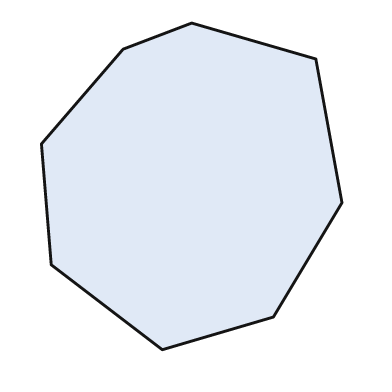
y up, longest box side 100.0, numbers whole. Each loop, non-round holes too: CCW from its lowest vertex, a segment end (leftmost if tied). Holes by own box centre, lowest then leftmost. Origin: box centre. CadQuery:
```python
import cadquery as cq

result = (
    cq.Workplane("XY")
    .moveTo(-9.0, -50.0)
    .lineTo(25.0, -40.0)
    .lineTo(46.0, -5.0)
    .lineTo(38.0, 39.0)
    .lineTo(0.0, 50.0)
    .lineTo(-21.0, 42.0)
    .lineTo(-46.0, 13.0)
    .lineTo(-43.0, -24.0)
    .close()
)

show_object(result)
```